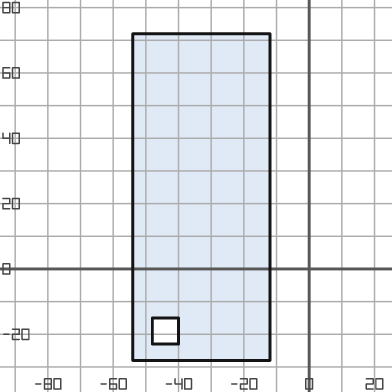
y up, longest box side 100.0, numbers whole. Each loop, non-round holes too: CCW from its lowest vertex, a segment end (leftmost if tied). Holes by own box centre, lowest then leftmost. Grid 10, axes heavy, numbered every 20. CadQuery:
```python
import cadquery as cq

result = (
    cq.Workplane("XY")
    .moveTo(-54.0, -28.0)
    .lineTo(-12.0, -28.0)
    .lineTo(-12.0, 72.0)
    .lineTo(-54.0, 72.0)
    .close()
    .moveTo(-48.0, -23.0)
    .lineTo(-40.0, -23.0)
    .lineTo(-40.0, -15.0)
    .lineTo(-48.0, -15.0)
    .close()
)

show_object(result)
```